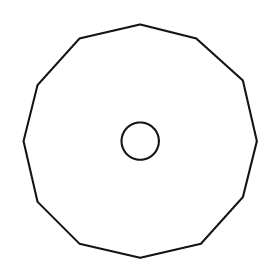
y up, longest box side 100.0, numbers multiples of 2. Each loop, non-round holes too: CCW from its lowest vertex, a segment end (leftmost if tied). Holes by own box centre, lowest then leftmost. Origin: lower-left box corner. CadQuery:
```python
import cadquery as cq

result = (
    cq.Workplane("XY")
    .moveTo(50.0, 0.0)
    .lineTo(76.0, 6.0)
    .lineTo(94.0, 26.0)
    .lineTo(100.0, 50.0)
    .lineTo(94.0, 76.0)
    .lineTo(74.0, 94.0)
    .lineTo(50.0, 100.0)
    .lineTo(24.0, 94.0)
    .lineTo(6.0, 74.0)
    .lineTo(0.0, 50.0)
    .lineTo(6.0, 24.0)
    .lineTo(24.0, 6.0)
    .close()
    .moveTo(50.0, 50.0)
    .circle(8.0)
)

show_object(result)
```